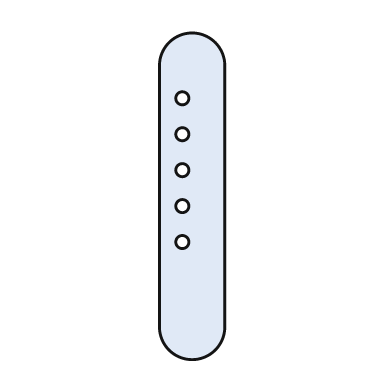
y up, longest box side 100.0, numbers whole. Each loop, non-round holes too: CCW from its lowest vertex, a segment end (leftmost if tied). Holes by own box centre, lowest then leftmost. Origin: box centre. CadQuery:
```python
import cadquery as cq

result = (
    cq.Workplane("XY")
    .moveTo(-10.0, -40.0)
    .threePointArc((0.0, -50.0), (10.0, -40.0))
    .lineTo(10.0, 40.0)
    .threePointArc((0.0, 50.0), (-10.0, 40.0))
    .close()
    .moveTo(-3.0, -14.0)
    .circle(2.0)
    .moveTo(-3.0, -3.0)
    .circle(2.0)
    .moveTo(-3.0, 8.0)
    .circle(2.0)
    .moveTo(-3.0, 19.0)
    .circle(2.0)
    .moveTo(-3.0, 30.0)
    .circle(2.0)
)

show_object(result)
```